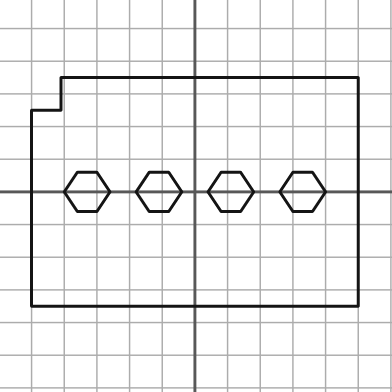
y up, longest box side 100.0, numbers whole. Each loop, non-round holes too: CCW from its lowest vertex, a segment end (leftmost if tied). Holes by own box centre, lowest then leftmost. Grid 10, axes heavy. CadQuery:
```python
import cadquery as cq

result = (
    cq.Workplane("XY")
    .moveTo(-50.0, -35.0)
    .lineTo(50.0, -35.0)
    .lineTo(50.0, 35.0)
    .lineTo(-41.0, 35.0)
    .lineTo(-41.0, 25.0)
    .lineTo(-50.0, 25.0)
    .close()
    .moveTo(-36.0, -6.0)
    .lineTo(-30.0, -6.0)
    .lineTo(-26.0, 0.0)
    .lineTo(-30.0, 6.0)
    .lineTo(-36.0, 6.0)
    .lineTo(-40.0, 0.0)
    .close()
    .moveTo(-14.0, -6.0)
    .lineTo(-8.0, -6.0)
    .lineTo(-4.0, 0.0)
    .lineTo(-8.0, 6.0)
    .lineTo(-14.0, 6.0)
    .lineTo(-18.0, 0.0)
    .close()
    .moveTo(8.0, -6.0)
    .lineTo(14.0, -6.0)
    .lineTo(18.0, 0.0)
    .lineTo(14.0, 6.0)
    .lineTo(8.0, 6.0)
    .lineTo(4.0, 0.0)
    .close()
    .moveTo(30.0, -6.0)
    .lineTo(36.0, -6.0)
    .lineTo(40.0, 0.0)
    .lineTo(36.0, 6.0)
    .lineTo(30.0, 6.0)
    .lineTo(26.0, 0.0)
    .close()
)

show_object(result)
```